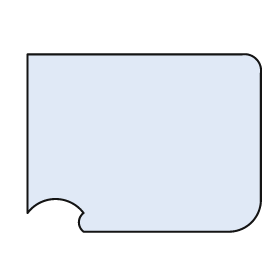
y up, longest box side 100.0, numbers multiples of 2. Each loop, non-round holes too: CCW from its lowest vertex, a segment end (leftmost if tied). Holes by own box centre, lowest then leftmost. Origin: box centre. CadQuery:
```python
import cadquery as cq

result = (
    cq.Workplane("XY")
    .moveTo(-26.0, -38.0)
    .lineTo(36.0, -38.0)
    .threePointArc((46.0, -34.0), (50.0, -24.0))
    .lineTo(50.0, 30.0)
    .threePointArc((48.0, 36.0), (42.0, 38.0))
    .lineTo(-50.0, 38.0)
    .lineTo(-50.0, -30.0)
    .threePointArc((-38.0, -24.0), (-26.0, -30.0))
    .threePointArc((-28.0, -34.0), (-26.0, -38.0))
    .close()
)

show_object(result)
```